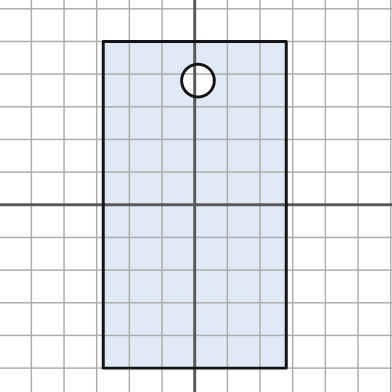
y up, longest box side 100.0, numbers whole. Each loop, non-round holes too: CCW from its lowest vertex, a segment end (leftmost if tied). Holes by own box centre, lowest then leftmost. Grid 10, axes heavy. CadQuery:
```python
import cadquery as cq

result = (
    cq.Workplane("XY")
    .moveTo(-28.0, -50.0)
    .lineTo(28.0, -50.0)
    .lineTo(28.0, 50.0)
    .lineTo(-28.0, 50.0)
    .close()
    .moveTo(1.0, 38.0)
    .circle(5.0)
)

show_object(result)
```